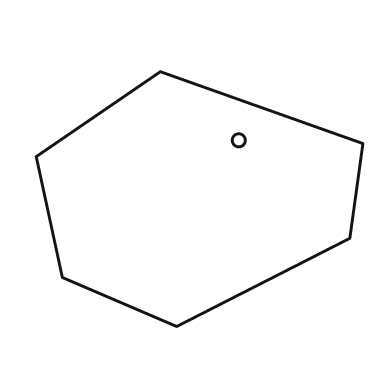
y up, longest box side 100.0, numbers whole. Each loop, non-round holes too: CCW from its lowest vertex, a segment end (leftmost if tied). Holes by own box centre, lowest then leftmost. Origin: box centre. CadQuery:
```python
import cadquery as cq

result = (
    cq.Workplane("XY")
    .moveTo(-7.0, -39.0)
    .lineTo(46.0, -12.0)
    .lineTo(50.0, 17.0)
    .lineTo(-12.0, 39.0)
    .lineTo(-50.0, 13.0)
    .lineTo(-42.0, -24.0)
    .close()
    .moveTo(12.0, 18.0)
    .circle(2.0)
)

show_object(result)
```